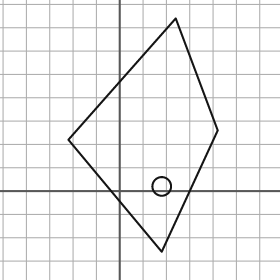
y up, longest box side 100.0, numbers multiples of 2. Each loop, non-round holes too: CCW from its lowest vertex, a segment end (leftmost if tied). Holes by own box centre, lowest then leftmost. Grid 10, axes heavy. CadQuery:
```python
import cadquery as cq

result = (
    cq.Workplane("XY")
    .moveTo(18.0, -26.0)
    .lineTo(42.0, 26.0)
    .lineTo(24.0, 74.0)
    .lineTo(-22.0, 22.0)
    .close()
    .moveTo(18.0, 2.0)
    .circle(4.0)
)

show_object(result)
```